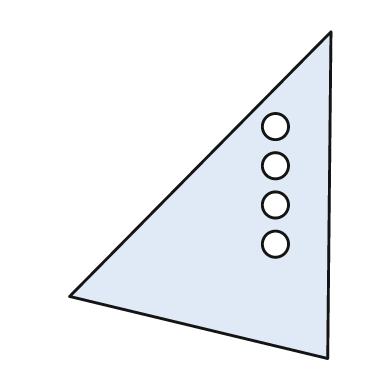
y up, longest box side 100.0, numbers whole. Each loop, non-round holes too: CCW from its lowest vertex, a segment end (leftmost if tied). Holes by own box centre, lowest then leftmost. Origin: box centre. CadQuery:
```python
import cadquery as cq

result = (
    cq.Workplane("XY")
    .moveTo(39.0, -50.0)
    .lineTo(40.0, 50.0)
    .lineTo(-40.0, -31.0)
    .close()
    .moveTo(23.0, -15.0)
    .circle(4.0)
    .moveTo(23.0, -3.0)
    .circle(4.0)
    .moveTo(23.0, 9.0)
    .circle(4.0)
    .moveTo(23.0, 21.0)
    .circle(4.0)
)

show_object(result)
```